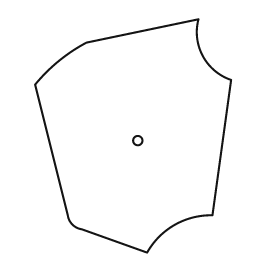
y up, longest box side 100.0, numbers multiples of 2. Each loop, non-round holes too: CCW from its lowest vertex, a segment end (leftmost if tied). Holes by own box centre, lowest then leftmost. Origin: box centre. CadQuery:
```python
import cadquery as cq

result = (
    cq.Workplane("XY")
    .moveTo(6.0, -50.0)
    .threePointArc((18.0, -38.0), (34.0, -34.0))
    .lineTo(42.0, 24.0)
    .threePointArc((30.0, 34.0), (28.0, 50.0))
    .lineTo(-20.0, 40.0)
    .threePointArc((-32.0, 32.0), (-42.0, 22.0))
    .lineTo(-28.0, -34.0)
    .threePointArc((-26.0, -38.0), (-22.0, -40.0))
    .close()
    .moveTo(2.0, -2.0)
    .circle(2.0)
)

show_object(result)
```